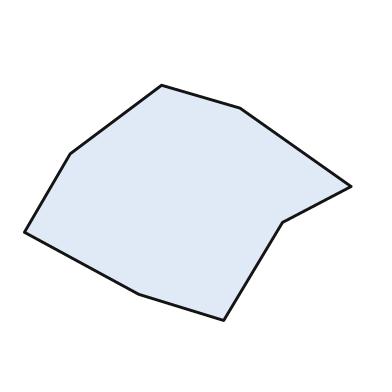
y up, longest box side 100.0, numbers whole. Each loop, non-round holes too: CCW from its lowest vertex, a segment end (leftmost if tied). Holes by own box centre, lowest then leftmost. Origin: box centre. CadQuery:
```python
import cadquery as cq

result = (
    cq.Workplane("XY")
    .moveTo(11.0, -36.0)
    .lineTo(29.0, -6.0)
    .lineTo(50.0, 5.0)
    .lineTo(16.0, 29.0)
    .lineTo(-8.0, 36.0)
    .lineTo(-36.0, 15.0)
    .lineTo(-50.0, -9.0)
    .lineTo(-15.0, -28.0)
    .close()
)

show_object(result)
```